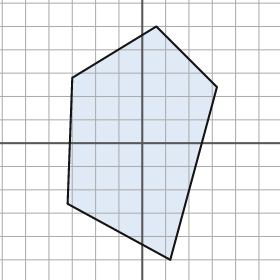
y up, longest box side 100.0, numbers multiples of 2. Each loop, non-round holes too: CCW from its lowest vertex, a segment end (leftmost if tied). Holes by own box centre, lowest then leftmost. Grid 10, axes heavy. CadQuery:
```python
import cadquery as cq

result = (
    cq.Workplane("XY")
    .moveTo(12.0, -50.0)
    .lineTo(32.0, 24.0)
    .lineTo(6.0, 50.0)
    .lineTo(-30.0, 28.0)
    .lineTo(-32.0, -26.0)
    .close()
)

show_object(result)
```